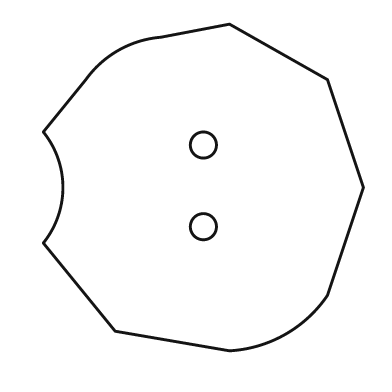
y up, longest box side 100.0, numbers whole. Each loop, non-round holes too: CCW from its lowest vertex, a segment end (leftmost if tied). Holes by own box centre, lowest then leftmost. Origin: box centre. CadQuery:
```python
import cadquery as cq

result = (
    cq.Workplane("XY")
    .moveTo(8.0, -50.0)
    .threePointArc((25.0, -45.0), (38.0, -33.0))
    .lineTo(49.0, 0.0)
    .lineTo(38.0, 33.0)
    .lineTo(8.0, 50.0)
    .lineTo(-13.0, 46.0)
    .threePointArc((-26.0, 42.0), (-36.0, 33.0))
    .lineTo(-49.0, 17.0)
    .threePointArc((-43.0, 0.0), (-49.0, -17.0))
    .lineTo(-27.0, -44.0)
    .close()
    .moveTo(0.0, -12.0)
    .circle(4.0)
    .moveTo(0.0, 13.0)
    .circle(4.0)
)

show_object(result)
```